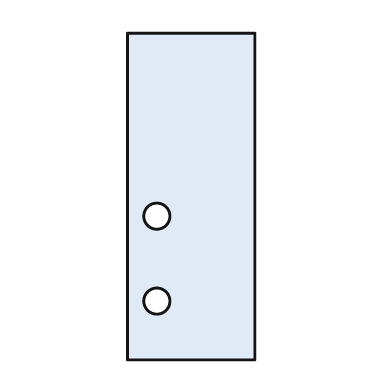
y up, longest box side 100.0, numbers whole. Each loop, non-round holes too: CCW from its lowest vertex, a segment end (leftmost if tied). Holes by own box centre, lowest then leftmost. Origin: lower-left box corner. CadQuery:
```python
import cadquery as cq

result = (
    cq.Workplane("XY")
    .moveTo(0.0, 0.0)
    .lineTo(39.0, 0.0)
    .lineTo(39.0, 100.0)
    .lineTo(0.0, 100.0)
    .close()
    .moveTo(9.0, 18.0)
    .circle(4.0)
    .moveTo(9.0, 44.0)
    .circle(4.0)
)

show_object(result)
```